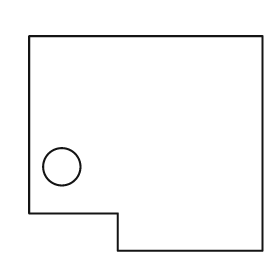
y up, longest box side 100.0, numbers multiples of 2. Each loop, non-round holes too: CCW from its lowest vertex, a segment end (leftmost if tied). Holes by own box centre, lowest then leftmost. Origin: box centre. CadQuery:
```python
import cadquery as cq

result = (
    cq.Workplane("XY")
    .moveTo(-12.0, -46.0)
    .lineTo(50.0, -46.0)
    .lineTo(50.0, 46.0)
    .lineTo(-50.0, 46.0)
    .lineTo(-50.0, -30.0)
    .lineTo(-12.0, -30.0)
    .close()
    .moveTo(-36.0, -10.0)
    .circle(8.0)
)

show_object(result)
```